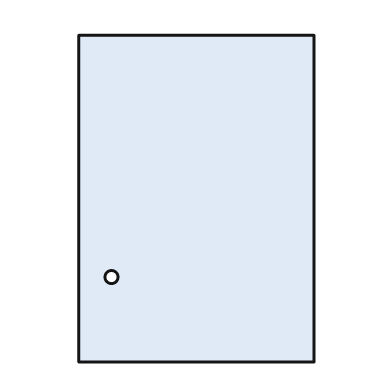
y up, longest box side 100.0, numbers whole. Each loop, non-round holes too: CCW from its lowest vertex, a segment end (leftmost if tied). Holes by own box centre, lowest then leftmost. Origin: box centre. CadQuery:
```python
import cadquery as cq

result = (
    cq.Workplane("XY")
    .moveTo(-36.0, -50.0)
    .lineTo(36.0, -50.0)
    .lineTo(36.0, 50.0)
    .lineTo(-36.0, 50.0)
    .close()
    .moveTo(-26.0, -24.0)
    .circle(2.0)
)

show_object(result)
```